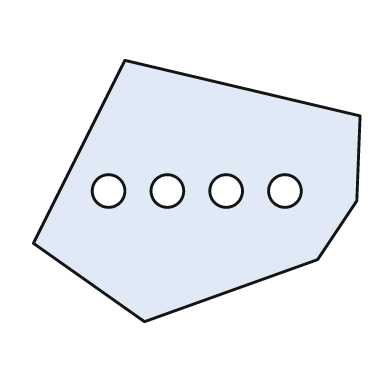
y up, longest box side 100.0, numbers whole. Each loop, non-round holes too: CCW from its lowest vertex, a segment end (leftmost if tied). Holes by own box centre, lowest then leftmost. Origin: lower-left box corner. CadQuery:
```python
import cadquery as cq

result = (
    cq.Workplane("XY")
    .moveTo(34.0, 0.0)
    .lineTo(87.0, 19.0)
    .lineTo(99.0, 37.0)
    .lineTo(100.0, 63.0)
    .lineTo(28.0, 80.0)
    .lineTo(0.0, 24.0)
    .close()
    .moveTo(23.0, 40.0)
    .circle(5.0)
    .moveTo(41.0, 40.0)
    .circle(5.0)
    .moveTo(59.0, 40.0)
    .circle(5.0)
    .moveTo(77.0, 40.0)
    .circle(5.0)
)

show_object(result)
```